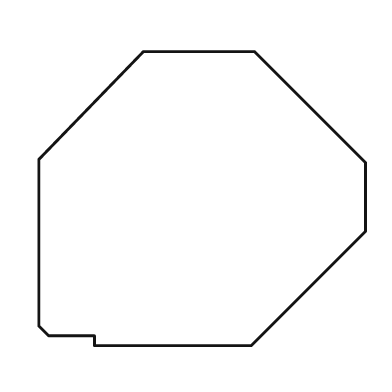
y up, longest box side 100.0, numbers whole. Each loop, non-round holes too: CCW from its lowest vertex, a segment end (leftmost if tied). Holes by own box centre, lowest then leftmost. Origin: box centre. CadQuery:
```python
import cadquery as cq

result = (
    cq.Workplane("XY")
    .moveTo(-33.0, -45.0)
    .lineTo(15.0, -45.0)
    .lineTo(50.0, -10.0)
    .lineTo(50.0, 11.0)
    .lineTo(16.0, 45.0)
    .lineTo(-18.0, 45.0)
    .lineTo(-50.0, 12.0)
    .lineTo(-50.0, -39.0)
    .lineTo(-47.0, -42.0)
    .lineTo(-33.0, -42.0)
    .close()
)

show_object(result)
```